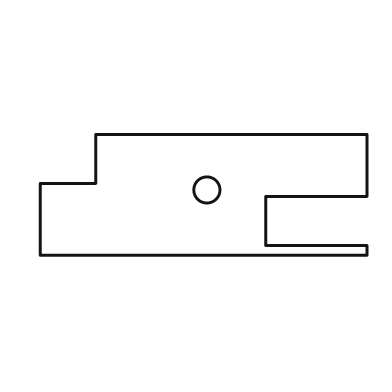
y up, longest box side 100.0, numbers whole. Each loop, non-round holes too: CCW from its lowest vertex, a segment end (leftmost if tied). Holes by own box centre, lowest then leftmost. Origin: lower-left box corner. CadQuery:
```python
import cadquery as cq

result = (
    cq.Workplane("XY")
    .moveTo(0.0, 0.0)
    .lineTo(100.0, 0.0)
    .lineTo(100.0, 3.0)
    .lineTo(69.0, 3.0)
    .lineTo(69.0, 18.0)
    .lineTo(100.0, 18.0)
    .lineTo(100.0, 37.0)
    .lineTo(17.0, 37.0)
    .lineTo(17.0, 22.0)
    .lineTo(0.0, 22.0)
    .close()
    .moveTo(51.0, 20.0)
    .circle(4.0)
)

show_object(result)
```